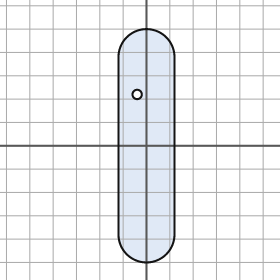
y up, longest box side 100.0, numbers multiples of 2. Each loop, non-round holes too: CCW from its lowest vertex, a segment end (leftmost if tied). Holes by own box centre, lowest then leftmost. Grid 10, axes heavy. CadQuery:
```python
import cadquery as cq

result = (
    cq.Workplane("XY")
    .moveTo(-12.0, -38.0)
    .threePointArc((0.0, -50.0), (12.0, -38.0))
    .lineTo(12.0, 38.0)
    .threePointArc((0.0, 50.0), (-12.0, 38.0))
    .close()
    .moveTo(-4.0, 22.0)
    .circle(2.0)
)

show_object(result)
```